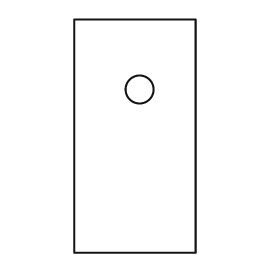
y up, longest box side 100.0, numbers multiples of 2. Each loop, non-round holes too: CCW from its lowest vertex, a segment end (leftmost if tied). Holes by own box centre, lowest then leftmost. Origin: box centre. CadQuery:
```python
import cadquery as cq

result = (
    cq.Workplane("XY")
    .moveTo(-26.0, -50.0)
    .lineTo(26.0, -50.0)
    .lineTo(26.0, 50.0)
    .lineTo(-26.0, 50.0)
    .close()
    .moveTo(2.0, 20.0)
    .circle(6.0)
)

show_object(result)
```